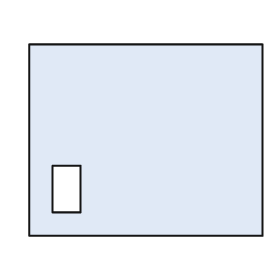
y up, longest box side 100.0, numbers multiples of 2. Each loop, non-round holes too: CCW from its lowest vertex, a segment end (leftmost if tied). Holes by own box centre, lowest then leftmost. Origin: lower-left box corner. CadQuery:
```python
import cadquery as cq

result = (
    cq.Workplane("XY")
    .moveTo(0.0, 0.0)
    .lineTo(100.0, 0.0)
    .lineTo(100.0, 82.0)
    .lineTo(0.0, 82.0)
    .close()
    .moveTo(10.0, 10.0)
    .lineTo(22.0, 10.0)
    .lineTo(22.0, 30.0)
    .lineTo(10.0, 30.0)
    .close()
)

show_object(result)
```